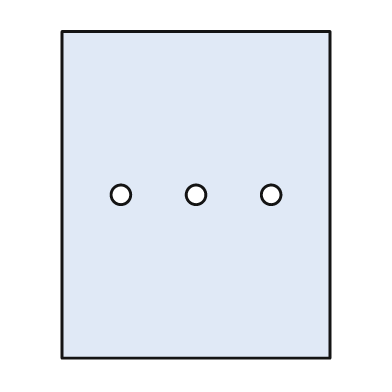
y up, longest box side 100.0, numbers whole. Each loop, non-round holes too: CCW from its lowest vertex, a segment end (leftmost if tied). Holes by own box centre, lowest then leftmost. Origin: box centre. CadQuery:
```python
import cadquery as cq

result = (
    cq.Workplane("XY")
    .moveTo(-41.0, -50.0)
    .lineTo(41.0, -50.0)
    .lineTo(41.0, 50.0)
    .lineTo(-41.0, 50.0)
    .close()
    .moveTo(-23.0, 0.0)
    .circle(3.0)
    .moveTo(0.0, 0.0)
    .circle(3.0)
    .moveTo(23.0, 0.0)
    .circle(3.0)
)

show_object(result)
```